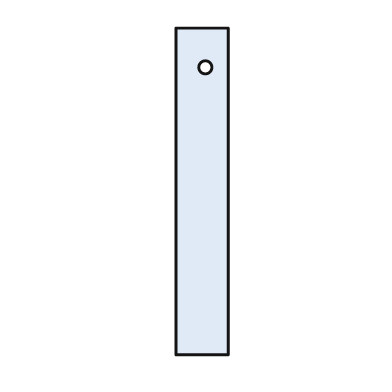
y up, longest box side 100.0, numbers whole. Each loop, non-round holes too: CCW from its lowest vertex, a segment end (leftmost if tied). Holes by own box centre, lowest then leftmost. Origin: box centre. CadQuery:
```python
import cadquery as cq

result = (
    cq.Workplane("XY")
    .moveTo(-8.0, -50.0)
    .lineTo(8.0, -50.0)
    .lineTo(8.0, 50.0)
    .lineTo(-8.0, 50.0)
    .close()
    .moveTo(1.0, 38.0)
    .circle(2.0)
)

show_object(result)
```